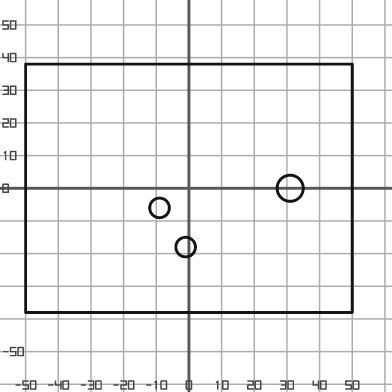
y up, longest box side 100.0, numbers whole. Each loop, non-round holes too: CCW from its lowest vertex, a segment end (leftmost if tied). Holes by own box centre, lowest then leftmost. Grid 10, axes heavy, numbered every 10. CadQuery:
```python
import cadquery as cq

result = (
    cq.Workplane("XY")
    .moveTo(-50.0, -38.0)
    .lineTo(50.0, -38.0)
    .lineTo(50.0, 38.0)
    .lineTo(-50.0, 38.0)
    .close()
    .moveTo(-1.0, -18.0)
    .circle(3.0)
    .moveTo(-9.0, -6.0)
    .circle(3.0)
    .moveTo(31.0, 0.0)
    .circle(4.0)
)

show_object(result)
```